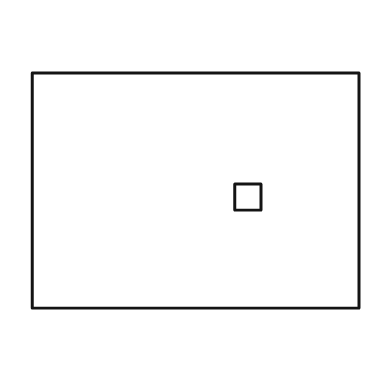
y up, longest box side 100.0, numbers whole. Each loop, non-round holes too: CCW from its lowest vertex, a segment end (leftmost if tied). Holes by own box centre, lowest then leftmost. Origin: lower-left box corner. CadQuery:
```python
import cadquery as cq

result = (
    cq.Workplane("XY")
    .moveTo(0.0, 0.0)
    .lineTo(100.0, 0.0)
    .lineTo(100.0, 72.0)
    .lineTo(0.0, 72.0)
    .close()
    .moveTo(62.0, 30.0)
    .lineTo(70.0, 30.0)
    .lineTo(70.0, 38.0)
    .lineTo(62.0, 38.0)
    .close()
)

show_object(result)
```